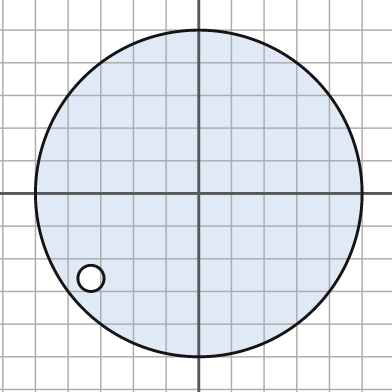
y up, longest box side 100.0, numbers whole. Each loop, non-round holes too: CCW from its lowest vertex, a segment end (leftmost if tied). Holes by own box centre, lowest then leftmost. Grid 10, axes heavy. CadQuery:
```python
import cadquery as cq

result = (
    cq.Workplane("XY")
    .moveTo(0.0, 0.0)
    .circle(50.0)
    .moveTo(-33.0, -26.0)
    .circle(4.0)
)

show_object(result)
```